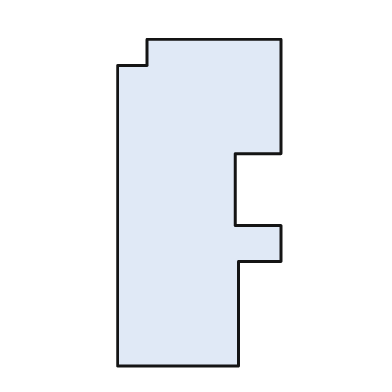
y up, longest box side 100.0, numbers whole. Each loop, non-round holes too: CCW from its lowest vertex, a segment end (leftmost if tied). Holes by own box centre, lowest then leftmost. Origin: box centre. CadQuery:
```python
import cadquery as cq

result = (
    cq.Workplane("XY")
    .moveTo(-25.0, -50.0)
    .lineTo(12.0, -50.0)
    .lineTo(12.0, -18.0)
    .lineTo(25.0, -18.0)
    .lineTo(25.0, -7.0)
    .lineTo(11.0, -7.0)
    .lineTo(11.0, 15.0)
    .lineTo(25.0, 15.0)
    .lineTo(25.0, 50.0)
    .lineTo(-16.0, 50.0)
    .lineTo(-16.0, 42.0)
    .lineTo(-25.0, 42.0)
    .close()
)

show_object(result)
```